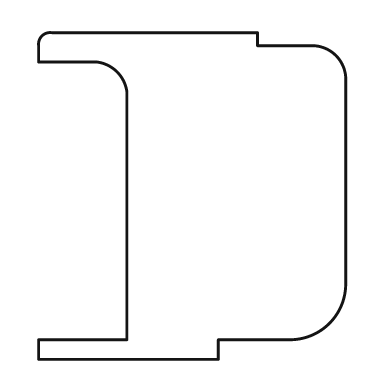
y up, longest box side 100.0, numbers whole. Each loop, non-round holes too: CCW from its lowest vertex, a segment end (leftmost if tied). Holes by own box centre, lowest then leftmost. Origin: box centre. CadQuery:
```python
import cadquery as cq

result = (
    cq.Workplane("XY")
    .moveTo(-47.0, -50.0)
    .lineTo(8.0, -50.0)
    .lineTo(8.0, -44.0)
    .lineTo(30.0, -44.0)
    .threePointArc((42.0, -39.0), (47.0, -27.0))
    .lineTo(47.0, 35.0)
    .threePointArc((44.0, 43.0), (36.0, 46.0))
    .lineTo(20.0, 46.0)
    .lineTo(20.0, 50.0)
    .lineTo(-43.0, 50.0)
    .threePointArc((-46.0, 49.0), (-47.0, 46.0))
    .lineTo(-47.0, 41.0)
    .lineTo(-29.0, 41.0)
    .threePointArc((-23.0, 38.0), (-20.0, 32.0))
    .lineTo(-20.0, -44.0)
    .lineTo(-47.0, -44.0)
    .close()
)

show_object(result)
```